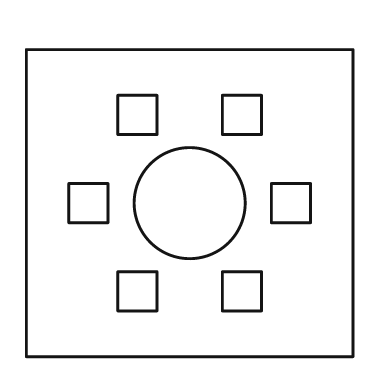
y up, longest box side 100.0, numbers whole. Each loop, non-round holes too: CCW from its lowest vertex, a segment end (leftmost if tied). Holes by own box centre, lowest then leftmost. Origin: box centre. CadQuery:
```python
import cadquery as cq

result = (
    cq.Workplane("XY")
    .moveTo(-50.0, -47.0)
    .lineTo(50.0, -47.0)
    .lineTo(50.0, 47.0)
    .lineTo(-50.0, 47.0)
    .close()
    .moveTo(-22.0, -33.0)
    .lineTo(-10.0, -33.0)
    .lineTo(-10.0, -21.0)
    .lineTo(-22.0, -21.0)
    .close()
    .moveTo(10.0, -33.0)
    .lineTo(22.0, -33.0)
    .lineTo(22.0, -21.0)
    .lineTo(10.0, -21.0)
    .close()
    .moveTo(-37.0, -6.0)
    .lineTo(-25.0, -6.0)
    .lineTo(-25.0, 6.0)
    .lineTo(-37.0, 6.0)
    .close()
    .moveTo(0.0, 0.0)
    .circle(17.0)
    .moveTo(25.0, -6.0)
    .lineTo(37.0, -6.0)
    .lineTo(37.0, 6.0)
    .lineTo(25.0, 6.0)
    .close()
    .moveTo(-22.0, 21.0)
    .lineTo(-10.0, 21.0)
    .lineTo(-10.0, 33.0)
    .lineTo(-22.0, 33.0)
    .close()
    .moveTo(10.0, 21.0)
    .lineTo(22.0, 21.0)
    .lineTo(22.0, 33.0)
    .lineTo(10.0, 33.0)
    .close()
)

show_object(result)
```